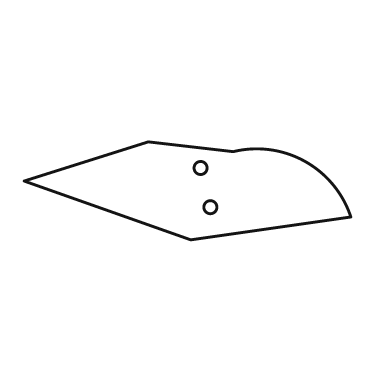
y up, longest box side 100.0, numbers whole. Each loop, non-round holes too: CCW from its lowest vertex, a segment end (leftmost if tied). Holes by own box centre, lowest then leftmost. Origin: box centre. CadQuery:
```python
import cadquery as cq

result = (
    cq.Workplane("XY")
    .moveTo(1.0, -15.0)
    .lineTo(50.0, -8.0)
    .threePointArc((36.0, 9.0), (14.0, 12.0))
    .lineTo(-12.0, 15.0)
    .lineTo(-50.0, 3.0)
    .close()
    .moveTo(7.0, -5.0)
    .circle(2.0)
    .moveTo(4.0, 7.0)
    .circle(2.0)
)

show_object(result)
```